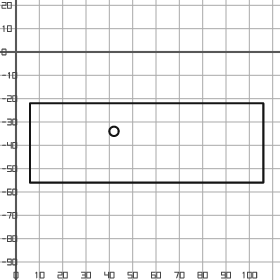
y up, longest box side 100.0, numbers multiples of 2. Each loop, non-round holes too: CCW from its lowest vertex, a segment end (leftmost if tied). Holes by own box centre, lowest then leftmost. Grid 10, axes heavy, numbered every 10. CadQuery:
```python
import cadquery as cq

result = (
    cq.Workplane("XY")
    .moveTo(6.0, -56.0)
    .lineTo(106.0, -56.0)
    .lineTo(106.0, -22.0)
    .lineTo(6.0, -22.0)
    .close()
    .moveTo(42.0, -34.0)
    .circle(2.0)
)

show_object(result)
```